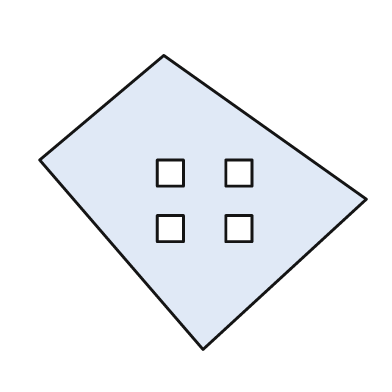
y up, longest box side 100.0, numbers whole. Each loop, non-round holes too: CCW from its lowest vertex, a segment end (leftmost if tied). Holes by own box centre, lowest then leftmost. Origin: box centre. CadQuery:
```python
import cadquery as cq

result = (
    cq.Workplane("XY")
    .moveTo(0.0, -45.0)
    .lineTo(50.0, 1.0)
    .lineTo(-12.0, 45.0)
    .lineTo(-50.0, 13.0)
    .close()
    .moveTo(-14.0, -12.0)
    .lineTo(-6.0, -12.0)
    .lineTo(-6.0, -4.0)
    .lineTo(-14.0, -4.0)
    .close()
    .moveTo(7.0, -12.0)
    .lineTo(15.0, -12.0)
    .lineTo(15.0, -4.0)
    .lineTo(7.0, -4.0)
    .close()
    .moveTo(-14.0, 5.0)
    .lineTo(-6.0, 5.0)
    .lineTo(-6.0, 13.0)
    .lineTo(-14.0, 13.0)
    .close()
    .moveTo(7.0, 5.0)
    .lineTo(15.0, 5.0)
    .lineTo(15.0, 13.0)
    .lineTo(7.0, 13.0)
    .close()
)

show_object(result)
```